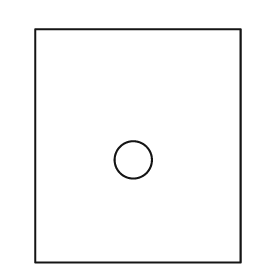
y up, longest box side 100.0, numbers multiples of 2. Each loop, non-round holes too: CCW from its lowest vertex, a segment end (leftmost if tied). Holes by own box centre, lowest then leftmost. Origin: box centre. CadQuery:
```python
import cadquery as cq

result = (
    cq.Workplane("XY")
    .moveTo(-44.0, -50.0)
    .lineTo(44.0, -50.0)
    .lineTo(44.0, 50.0)
    .lineTo(-44.0, 50.0)
    .close()
    .moveTo(-2.0, -6.0)
    .circle(8.0)
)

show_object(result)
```